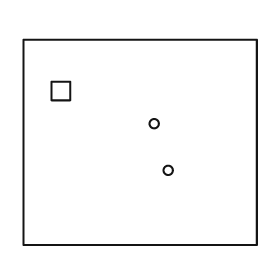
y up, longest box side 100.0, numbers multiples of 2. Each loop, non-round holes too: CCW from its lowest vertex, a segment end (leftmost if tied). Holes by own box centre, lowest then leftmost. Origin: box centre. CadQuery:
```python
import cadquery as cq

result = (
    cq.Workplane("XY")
    .moveTo(-50.0, -44.0)
    .lineTo(50.0, -44.0)
    .lineTo(50.0, 44.0)
    .lineTo(-50.0, 44.0)
    .close()
    .moveTo(12.0, -12.0)
    .circle(2.0)
    .moveTo(6.0, 8.0)
    .circle(2.0)
    .moveTo(-38.0, 18.0)
    .lineTo(-30.0, 18.0)
    .lineTo(-30.0, 26.0)
    .lineTo(-38.0, 26.0)
    .close()
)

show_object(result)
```